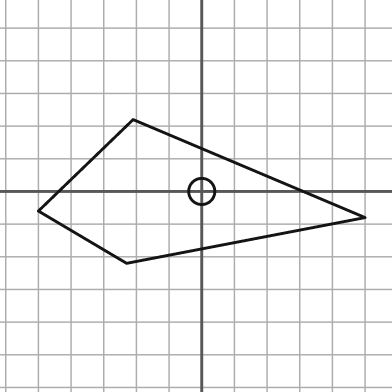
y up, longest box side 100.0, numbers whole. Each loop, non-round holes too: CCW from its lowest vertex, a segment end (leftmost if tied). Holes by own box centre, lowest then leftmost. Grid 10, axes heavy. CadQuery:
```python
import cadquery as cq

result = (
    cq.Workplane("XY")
    .moveTo(-23.0, -22.0)
    .lineTo(50.0, -8.0)
    .lineTo(-21.0, 22.0)
    .lineTo(-50.0, -6.0)
    .close()
    .moveTo(0.0, 0.0)
    .circle(4.0)
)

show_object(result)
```